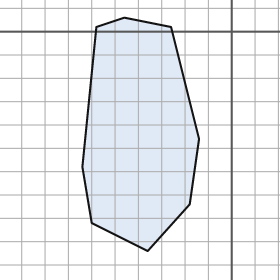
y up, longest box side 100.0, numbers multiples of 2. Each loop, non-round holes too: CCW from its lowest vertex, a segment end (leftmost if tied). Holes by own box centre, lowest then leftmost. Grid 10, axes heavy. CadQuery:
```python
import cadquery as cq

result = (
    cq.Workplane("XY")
    .moveTo(-36.0, -94.0)
    .lineTo(-18.0, -74.0)
    .lineTo(-14.0, -46.0)
    .lineTo(-26.0, 2.0)
    .lineTo(-46.0, 6.0)
    .lineTo(-58.0, 2.0)
    .lineTo(-64.0, -58.0)
    .lineTo(-60.0, -82.0)
    .close()
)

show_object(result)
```